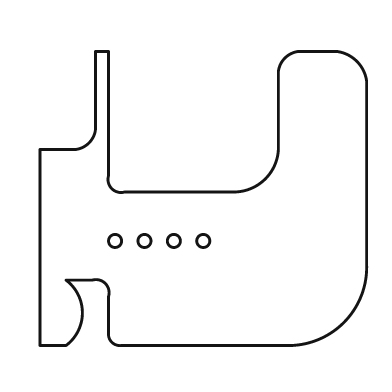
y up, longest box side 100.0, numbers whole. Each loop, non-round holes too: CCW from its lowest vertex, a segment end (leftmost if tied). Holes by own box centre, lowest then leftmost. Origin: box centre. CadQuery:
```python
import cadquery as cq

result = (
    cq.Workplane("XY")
    .moveTo(-50.0, -45.0)
    .lineTo(-42.0, -45.0)
    .threePointArc((-37.0, -35.0), (-42.0, -25.0))
    .lineTo(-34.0, -25.0)
    .threePointArc((-30.0, -26.0), (-29.0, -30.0))
    .lineTo(-29.0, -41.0)
    .threePointArc((-28.0, -44.0), (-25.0, -45.0))
    .lineTo(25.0, -45.0)
    .threePointArc((43.0, -38.0), (50.0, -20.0))
    .lineTo(50.0, 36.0)
    .threePointArc((47.0, 42.0), (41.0, 45.0))
    .lineTo(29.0, 45.0)
    .threePointArc((25.0, 43.0), (23.0, 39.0))
    .lineTo(23.0, 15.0)
    .threePointArc((19.0, 6.0), (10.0, 2.0))
    .lineTo(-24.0, 2.0)
    .threePointArc((-28.0, 3.0), (-29.0, 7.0))
    .lineTo(-29.0, 45.0)
    .lineTo(-33.0, 45.0)
    .lineTo(-33.0, 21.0)
    .threePointArc((-35.0, 17.0), (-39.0, 15.0))
    .lineTo(-50.0, 15.0)
    .close()
    .moveTo(-27.0, -13.0)
    .circle(2.0)
    .moveTo(-18.0, -13.0)
    .circle(2.0)
    .moveTo(-9.0, -13.0)
    .circle(2.0)
    .moveTo(0.0, -13.0)
    .circle(2.0)
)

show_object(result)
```